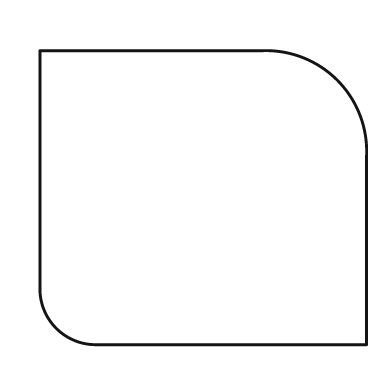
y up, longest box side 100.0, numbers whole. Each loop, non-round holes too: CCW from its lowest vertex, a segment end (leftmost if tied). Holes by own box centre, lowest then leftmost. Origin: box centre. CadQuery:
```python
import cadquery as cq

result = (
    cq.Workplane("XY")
    .moveTo(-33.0, -45.0)
    .lineTo(50.0, -45.0)
    .lineTo(50.0, 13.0)
    .threePointArc((41.0, 36.0), (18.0, 45.0))
    .lineTo(-50.0, 45.0)
    .lineTo(-50.0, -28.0)
    .threePointArc((-45.0, -40.0), (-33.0, -45.0))
    .close()
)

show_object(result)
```